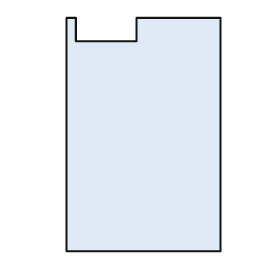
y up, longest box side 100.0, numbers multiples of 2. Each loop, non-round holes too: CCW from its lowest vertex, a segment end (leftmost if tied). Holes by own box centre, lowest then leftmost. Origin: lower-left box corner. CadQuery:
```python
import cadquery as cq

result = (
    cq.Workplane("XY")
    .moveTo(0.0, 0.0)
    .lineTo(66.0, 0.0)
    .lineTo(66.0, 100.0)
    .lineTo(30.0, 100.0)
    .lineTo(30.0, 90.0)
    .lineTo(4.0, 90.0)
    .lineTo(4.0, 100.0)
    .lineTo(0.0, 100.0)
    .close()
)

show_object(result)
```